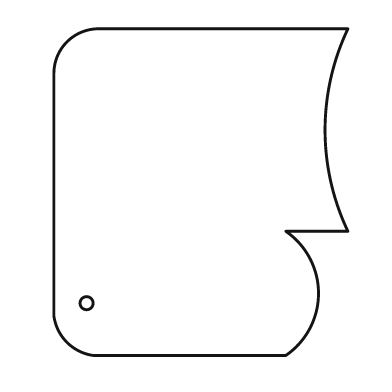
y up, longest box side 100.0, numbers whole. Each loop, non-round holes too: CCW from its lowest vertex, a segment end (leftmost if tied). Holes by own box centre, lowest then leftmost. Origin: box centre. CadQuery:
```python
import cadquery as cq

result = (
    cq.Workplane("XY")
    .moveTo(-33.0, -50.0)
    .lineTo(26.0, -50.0)
    .threePointArc((36.0, -31.0), (26.0, -12.0))
    .lineTo(45.0, -12.0)
    .threePointArc((38.0, 19.0), (45.0, 50.0))
    .lineTo(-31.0, 50.0)
    .threePointArc((-41.0, 46.0), (-45.0, 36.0))
    .lineTo(-45.0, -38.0)
    .threePointArc((-41.0, -46.0), (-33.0, -50.0))
    .close()
    .moveTo(-35.0, -34.0)
    .circle(2.0)
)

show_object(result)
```